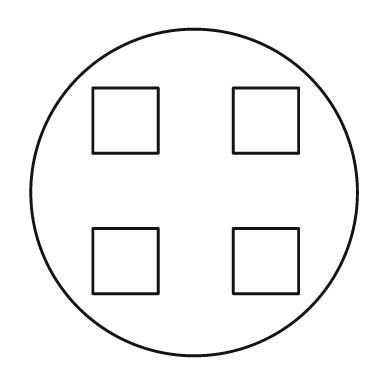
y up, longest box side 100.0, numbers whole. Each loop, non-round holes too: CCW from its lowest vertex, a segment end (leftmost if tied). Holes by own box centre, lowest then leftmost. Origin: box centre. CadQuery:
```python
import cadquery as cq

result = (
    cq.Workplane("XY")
    .moveTo(0.0, 0.0)
    .circle(50.0)
    .moveTo(-31.0, -31.0)
    .lineTo(-11.0, -31.0)
    .lineTo(-11.0, -11.0)
    .lineTo(-31.0, -11.0)
    .close()
    .moveTo(12.0, -31.0)
    .lineTo(32.0, -31.0)
    .lineTo(32.0, -11.0)
    .lineTo(12.0, -11.0)
    .close()
    .moveTo(-31.0, 12.0)
    .lineTo(-11.0, 12.0)
    .lineTo(-11.0, 32.0)
    .lineTo(-31.0, 32.0)
    .close()
    .moveTo(12.0, 12.0)
    .lineTo(32.0, 12.0)
    .lineTo(32.0, 32.0)
    .lineTo(12.0, 32.0)
    .close()
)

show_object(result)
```